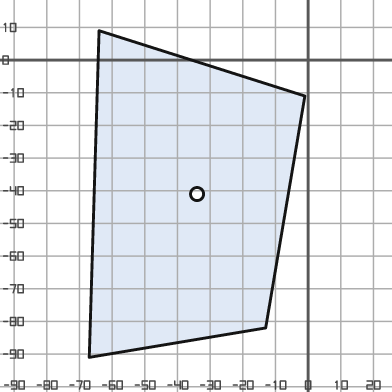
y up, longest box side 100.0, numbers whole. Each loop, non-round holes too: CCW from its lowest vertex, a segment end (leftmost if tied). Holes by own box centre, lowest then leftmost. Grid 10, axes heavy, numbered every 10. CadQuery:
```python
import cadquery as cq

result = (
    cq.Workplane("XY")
    .moveTo(-67.0, -91.0)
    .lineTo(-13.0, -82.0)
    .lineTo(-1.0, -11.0)
    .lineTo(-64.0, 9.0)
    .close()
    .moveTo(-34.0, -41.0)
    .circle(2.0)
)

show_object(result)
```